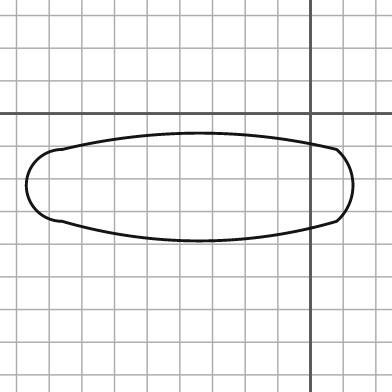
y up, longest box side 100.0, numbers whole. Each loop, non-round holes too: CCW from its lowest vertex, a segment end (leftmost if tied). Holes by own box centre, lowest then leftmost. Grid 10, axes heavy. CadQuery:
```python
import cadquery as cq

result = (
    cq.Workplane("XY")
    .moveTo(-76.0, -33.0)
    .threePointArc((-34.0, -39.0), (8.0, -33.0))
    .threePointArc((13.0, -22.0), (8.0, -11.0))
    .threePointArc((-34.0, -6.0), (-76.0, -11.0))
    .threePointArc((-87.0, -22.0), (-76.0, -33.0))
    .close()
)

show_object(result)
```